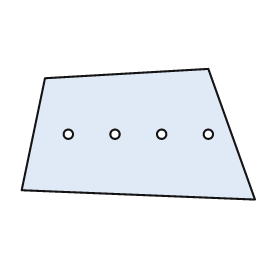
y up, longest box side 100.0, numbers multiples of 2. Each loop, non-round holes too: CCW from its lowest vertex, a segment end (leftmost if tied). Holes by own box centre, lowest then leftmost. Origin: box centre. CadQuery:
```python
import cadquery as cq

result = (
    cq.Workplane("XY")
    .moveTo(50.0, -28.0)
    .lineTo(30.0, 28.0)
    .lineTo(-40.0, 24.0)
    .lineTo(-50.0, -24.0)
    .close()
    .moveTo(-30.0, 0.0)
    .circle(2.0)
    .moveTo(-10.0, 0.0)
    .circle(2.0)
    .moveTo(10.0, 0.0)
    .circle(2.0)
    .moveTo(30.0, 0.0)
    .circle(2.0)
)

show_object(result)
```